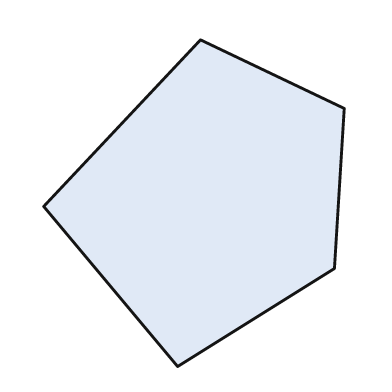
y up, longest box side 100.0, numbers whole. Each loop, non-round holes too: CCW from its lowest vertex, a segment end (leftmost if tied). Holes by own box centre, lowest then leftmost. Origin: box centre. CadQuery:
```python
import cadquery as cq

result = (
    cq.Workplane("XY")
    .moveTo(-5.0, -50.0)
    .lineTo(43.0, -20.0)
    .lineTo(46.0, 29.0)
    .lineTo(2.0, 50.0)
    .lineTo(-46.0, -1.0)
    .close()
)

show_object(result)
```